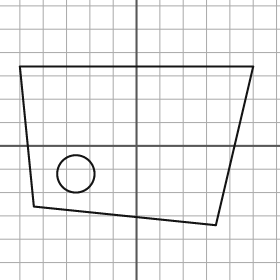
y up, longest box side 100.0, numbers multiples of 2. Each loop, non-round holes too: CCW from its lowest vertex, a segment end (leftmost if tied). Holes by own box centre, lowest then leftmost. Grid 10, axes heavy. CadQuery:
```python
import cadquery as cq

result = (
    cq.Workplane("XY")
    .moveTo(34.0, -34.0)
    .lineTo(50.0, 34.0)
    .lineTo(-50.0, 34.0)
    .lineTo(-44.0, -26.0)
    .close()
    .moveTo(-26.0, -12.0)
    .circle(8.0)
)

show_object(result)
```